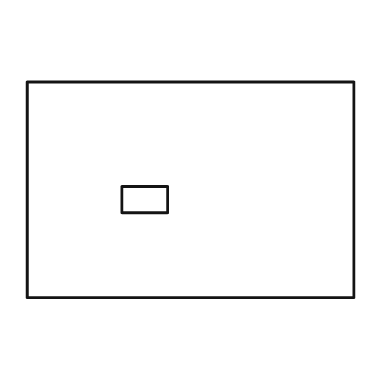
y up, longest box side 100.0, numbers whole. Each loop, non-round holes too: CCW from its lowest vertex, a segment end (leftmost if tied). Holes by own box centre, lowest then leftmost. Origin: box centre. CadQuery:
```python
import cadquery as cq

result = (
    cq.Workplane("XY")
    .moveTo(-50.0, -33.0)
    .lineTo(50.0, -33.0)
    .lineTo(50.0, 33.0)
    .lineTo(-50.0, 33.0)
    .close()
    .moveTo(-21.0, -7.0)
    .lineTo(-7.0, -7.0)
    .lineTo(-7.0, 1.0)
    .lineTo(-21.0, 1.0)
    .close()
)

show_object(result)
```